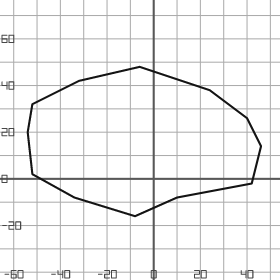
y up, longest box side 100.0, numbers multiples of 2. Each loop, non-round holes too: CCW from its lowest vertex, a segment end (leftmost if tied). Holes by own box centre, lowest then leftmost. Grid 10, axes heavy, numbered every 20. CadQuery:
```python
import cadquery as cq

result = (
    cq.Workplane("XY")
    .moveTo(-8.0, -16.0)
    .lineTo(10.0, -8.0)
    .lineTo(42.0, -2.0)
    .lineTo(46.0, 14.0)
    .lineTo(40.0, 26.0)
    .lineTo(24.0, 38.0)
    .lineTo(-6.0, 48.0)
    .lineTo(-32.0, 42.0)
    .lineTo(-52.0, 32.0)
    .lineTo(-54.0, 20.0)
    .lineTo(-52.0, 2.0)
    .lineTo(-34.0, -8.0)
    .close()
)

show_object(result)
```